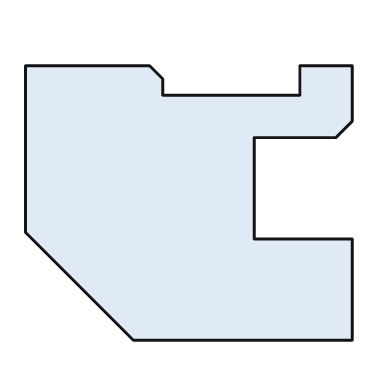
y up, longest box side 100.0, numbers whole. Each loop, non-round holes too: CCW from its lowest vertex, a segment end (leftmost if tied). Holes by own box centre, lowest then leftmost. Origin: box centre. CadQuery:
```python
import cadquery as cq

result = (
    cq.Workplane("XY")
    .moveTo(-17.0, -42.0)
    .lineTo(50.0, -42.0)
    .lineTo(50.0, -11.0)
    .lineTo(20.0, -11.0)
    .lineTo(20.0, 20.0)
    .lineTo(45.0, 20.0)
    .lineTo(50.0, 25.0)
    .lineTo(50.0, 42.0)
    .lineTo(34.0, 42.0)
    .lineTo(34.0, 33.0)
    .lineTo(-8.0, 33.0)
    .lineTo(-8.0, 38.0)
    .lineTo(-12.0, 42.0)
    .lineTo(-50.0, 42.0)
    .lineTo(-50.0, -9.0)
    .close()
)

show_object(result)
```